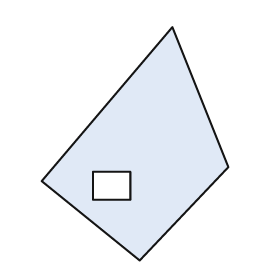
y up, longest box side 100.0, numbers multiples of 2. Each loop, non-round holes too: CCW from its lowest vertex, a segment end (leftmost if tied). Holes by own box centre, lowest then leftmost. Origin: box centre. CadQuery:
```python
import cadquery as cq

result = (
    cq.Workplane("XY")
    .moveTo(2.0, -50.0)
    .lineTo(40.0, -10.0)
    .lineTo(16.0, 50.0)
    .lineTo(-40.0, -16.0)
    .close()
    .moveTo(-18.0, -24.0)
    .lineTo(-2.0, -24.0)
    .lineTo(-2.0, -12.0)
    .lineTo(-18.0, -12.0)
    .close()
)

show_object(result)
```